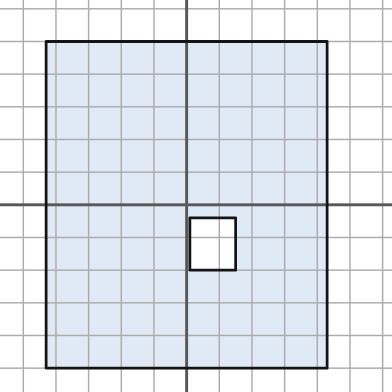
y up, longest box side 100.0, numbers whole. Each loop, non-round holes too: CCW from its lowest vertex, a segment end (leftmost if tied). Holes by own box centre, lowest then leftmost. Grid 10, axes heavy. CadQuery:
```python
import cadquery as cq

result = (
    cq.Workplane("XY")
    .moveTo(-43.0, -50.0)
    .lineTo(43.0, -50.0)
    .lineTo(43.0, 50.0)
    .lineTo(-43.0, 50.0)
    .close()
    .moveTo(1.0, -20.0)
    .lineTo(15.0, -20.0)
    .lineTo(15.0, -4.0)
    .lineTo(1.0, -4.0)
    .close()
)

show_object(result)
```